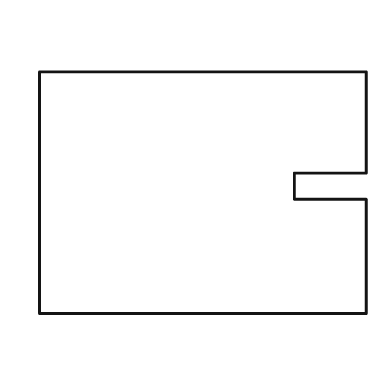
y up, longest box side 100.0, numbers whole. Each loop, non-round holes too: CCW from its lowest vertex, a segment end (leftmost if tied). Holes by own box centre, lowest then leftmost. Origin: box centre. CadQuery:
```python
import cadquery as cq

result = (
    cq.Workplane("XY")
    .moveTo(-50.0, -37.0)
    .lineTo(50.0, -37.0)
    .lineTo(50.0, -2.0)
    .lineTo(28.0, -2.0)
    .lineTo(28.0, 6.0)
    .lineTo(50.0, 6.0)
    .lineTo(50.0, 37.0)
    .lineTo(-50.0, 37.0)
    .close()
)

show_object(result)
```